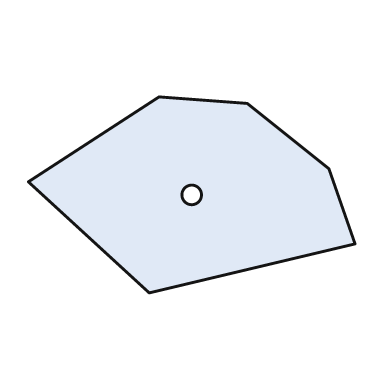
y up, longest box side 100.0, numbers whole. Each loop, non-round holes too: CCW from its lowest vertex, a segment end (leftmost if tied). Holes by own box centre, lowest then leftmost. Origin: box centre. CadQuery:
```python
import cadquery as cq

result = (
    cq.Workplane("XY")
    .moveTo(-13.0, -30.0)
    .lineTo(50.0, -15.0)
    .lineTo(42.0, 8.0)
    .lineTo(17.0, 28.0)
    .lineTo(-10.0, 30.0)
    .lineTo(-50.0, 4.0)
    .close()
    .moveTo(0.0, 0.0)
    .circle(3.0)
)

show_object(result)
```